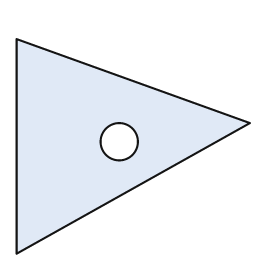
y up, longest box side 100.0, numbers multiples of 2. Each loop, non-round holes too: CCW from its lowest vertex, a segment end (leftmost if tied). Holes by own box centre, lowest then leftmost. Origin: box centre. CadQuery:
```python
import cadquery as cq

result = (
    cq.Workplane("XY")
    .moveTo(-50.0, -46.0)
    .lineTo(50.0, 10.0)
    .lineTo(-50.0, 46.0)
    .close()
    .moveTo(-6.0, 2.0)
    .circle(8.0)
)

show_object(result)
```